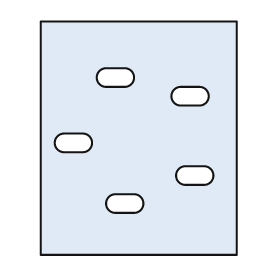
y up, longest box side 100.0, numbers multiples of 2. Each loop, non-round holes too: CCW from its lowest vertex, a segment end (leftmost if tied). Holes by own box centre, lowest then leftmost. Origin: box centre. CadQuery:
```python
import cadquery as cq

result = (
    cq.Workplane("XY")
    .moveTo(-42.0, -50.0)
    .lineTo(42.0, -50.0)
    .lineTo(42.0, 50.0)
    .lineTo(-42.0, 50.0)
    .close()
    .moveTo(-10.0, -32.0)
    .lineTo(-2.0, -32.0)
    .threePointArc((2.0, -28.0), (-2.0, -24.0))
    .lineTo(-10.0, -24.0)
    .threePointArc((-14.0, -28.0), (-10.0, -32.0))
    .close()
    .moveTo(20.0, -20.0)
    .lineTo(28.0, -20.0)
    .threePointArc((32.0, -16.0), (28.0, -12.0))
    .lineTo(20.0, -12.0)
    .threePointArc((16.0, -16.0), (20.0, -20.0))
    .close()
    .moveTo(-32.0, -6.0)
    .lineTo(-24.0, -6.0)
    .threePointArc((-20.0, -2.0), (-24.0, 2.0))
    .lineTo(-32.0, 2.0)
    .threePointArc((-36.0, -2.0), (-32.0, -6.0))
    .close()
    .moveTo(18.0, 14.0)
    .lineTo(26.0, 14.0)
    .threePointArc((30.0, 18.0), (26.0, 22.0))
    .lineTo(18.0, 22.0)
    .threePointArc((14.0, 18.0), (18.0, 14.0))
    .close()
    .moveTo(-14.0, 22.0)
    .lineTo(-6.0, 22.0)
    .threePointArc((-2.0, 26.0), (-6.0, 30.0))
    .lineTo(-14.0, 30.0)
    .threePointArc((-18.0, 26.0), (-14.0, 22.0))
    .close()
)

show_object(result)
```